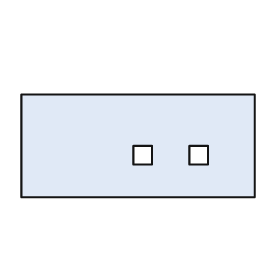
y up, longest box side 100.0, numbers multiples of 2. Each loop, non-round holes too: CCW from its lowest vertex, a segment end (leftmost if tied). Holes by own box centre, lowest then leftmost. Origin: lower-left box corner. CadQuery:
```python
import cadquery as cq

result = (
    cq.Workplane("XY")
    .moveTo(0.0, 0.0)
    .lineTo(100.0, 0.0)
    .lineTo(100.0, 44.0)
    .lineTo(0.0, 44.0)
    .close()
    .moveTo(48.0, 14.0)
    .lineTo(56.0, 14.0)
    .lineTo(56.0, 22.0)
    .lineTo(48.0, 22.0)
    .close()
    .moveTo(72.0, 14.0)
    .lineTo(80.0, 14.0)
    .lineTo(80.0, 22.0)
    .lineTo(72.0, 22.0)
    .close()
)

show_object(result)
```